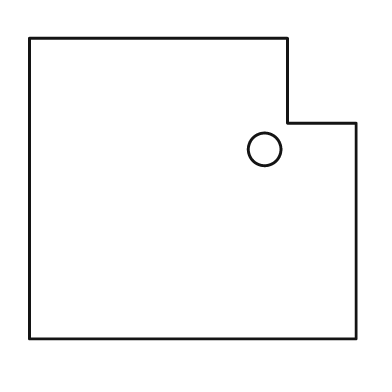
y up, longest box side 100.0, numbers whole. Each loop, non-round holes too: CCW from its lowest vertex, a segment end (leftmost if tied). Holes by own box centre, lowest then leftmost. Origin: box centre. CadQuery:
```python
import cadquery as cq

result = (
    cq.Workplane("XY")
    .moveTo(-50.0, -46.0)
    .lineTo(50.0, -46.0)
    .lineTo(50.0, 20.0)
    .lineTo(29.0, 20.0)
    .lineTo(29.0, 46.0)
    .lineTo(-50.0, 46.0)
    .close()
    .moveTo(22.0, 12.0)
    .circle(5.0)
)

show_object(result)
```